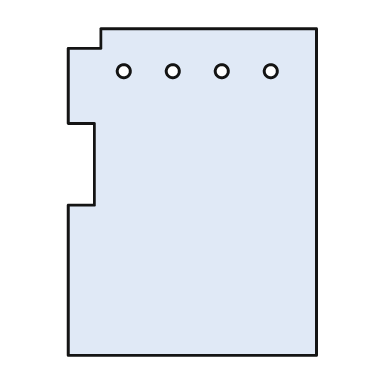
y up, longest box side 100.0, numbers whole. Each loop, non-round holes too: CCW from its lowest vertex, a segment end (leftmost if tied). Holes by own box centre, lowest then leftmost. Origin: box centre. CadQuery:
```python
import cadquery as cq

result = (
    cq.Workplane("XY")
    .moveTo(-38.0, -50.0)
    .lineTo(38.0, -50.0)
    .lineTo(38.0, 50.0)
    .lineTo(-28.0, 50.0)
    .lineTo(-28.0, 44.0)
    .lineTo(-38.0, 44.0)
    .lineTo(-38.0, 21.0)
    .lineTo(-30.0, 21.0)
    .lineTo(-30.0, -4.0)
    .lineTo(-38.0, -4.0)
    .close()
    .moveTo(-21.0, 37.0)
    .circle(2.0)
    .moveTo(-6.0, 37.0)
    .circle(2.0)
    .moveTo(9.0, 37.0)
    .circle(2.0)
    .moveTo(24.0, 37.0)
    .circle(2.0)
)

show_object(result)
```